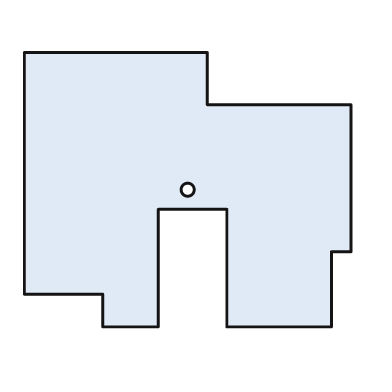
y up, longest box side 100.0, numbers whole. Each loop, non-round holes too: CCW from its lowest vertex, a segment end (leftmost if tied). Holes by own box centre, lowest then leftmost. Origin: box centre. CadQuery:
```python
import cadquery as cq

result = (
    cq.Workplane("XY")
    .moveTo(-26.0, -42.0)
    .lineTo(-9.0, -42.0)
    .lineTo(-9.0, -6.0)
    .lineTo(12.0, -6.0)
    .lineTo(12.0, -42.0)
    .lineTo(44.0, -42.0)
    .lineTo(44.0, -19.0)
    .lineTo(50.0, -19.0)
    .lineTo(50.0, 26.0)
    .lineTo(6.0, 26.0)
    .lineTo(6.0, 42.0)
    .lineTo(-50.0, 42.0)
    .lineTo(-50.0, -32.0)
    .lineTo(-26.0, -32.0)
    .close()
    .moveTo(0.0, 0.0)
    .circle(2.0)
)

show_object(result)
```